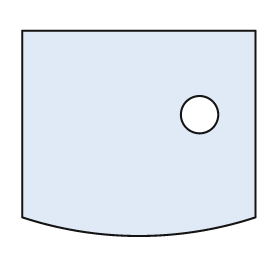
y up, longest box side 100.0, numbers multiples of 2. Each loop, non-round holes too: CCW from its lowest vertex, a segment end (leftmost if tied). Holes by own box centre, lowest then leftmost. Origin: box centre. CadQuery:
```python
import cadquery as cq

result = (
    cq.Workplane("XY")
    .moveTo(-50.0, -36.0)
    .threePointArc((0.0, -44.0), (50.0, -36.0))
    .lineTo(50.0, 44.0)
    .lineTo(-50.0, 44.0)
    .close()
    .moveTo(26.0, 8.0)
    .circle(8.0)
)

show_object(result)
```